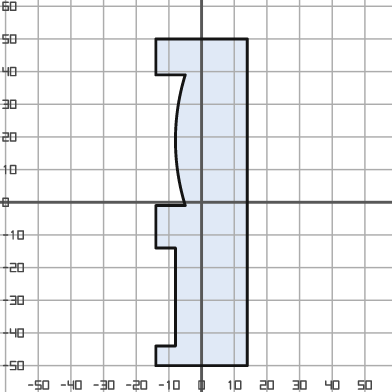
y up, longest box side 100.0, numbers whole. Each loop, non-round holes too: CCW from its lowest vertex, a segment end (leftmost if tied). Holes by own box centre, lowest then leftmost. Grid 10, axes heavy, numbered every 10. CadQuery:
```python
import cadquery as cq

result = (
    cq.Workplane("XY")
    .moveTo(-14.0, -50.0)
    .lineTo(14.0, -50.0)
    .lineTo(14.0, 50.0)
    .lineTo(-14.0, 50.0)
    .lineTo(-14.0, 39.0)
    .lineTo(-5.0, 39.0)
    .threePointArc((-8.0, 19.0), (-5.0, -1.0))
    .lineTo(-14.0, -1.0)
    .lineTo(-14.0, -14.0)
    .lineTo(-8.0, -14.0)
    .lineTo(-8.0, -44.0)
    .lineTo(-14.0, -44.0)
    .close()
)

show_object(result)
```